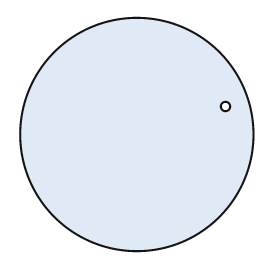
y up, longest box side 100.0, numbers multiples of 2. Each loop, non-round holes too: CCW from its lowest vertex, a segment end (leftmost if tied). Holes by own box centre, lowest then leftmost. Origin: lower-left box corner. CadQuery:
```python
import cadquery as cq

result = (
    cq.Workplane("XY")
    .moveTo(50.0, 50.0)
    .circle(50.0)
    .moveTo(88.0, 62.0)
    .circle(2.0)
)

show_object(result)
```